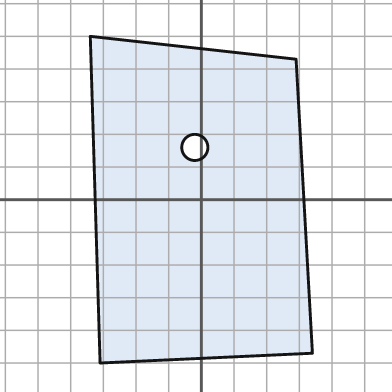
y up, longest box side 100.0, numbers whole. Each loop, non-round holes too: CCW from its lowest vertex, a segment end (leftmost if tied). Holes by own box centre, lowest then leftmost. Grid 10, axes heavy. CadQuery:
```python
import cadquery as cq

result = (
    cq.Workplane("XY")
    .moveTo(-31.0, -50.0)
    .lineTo(34.0, -47.0)
    .lineTo(29.0, 43.0)
    .lineTo(-34.0, 50.0)
    .close()
    .moveTo(-2.0, 16.0)
    .circle(4.0)
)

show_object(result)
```